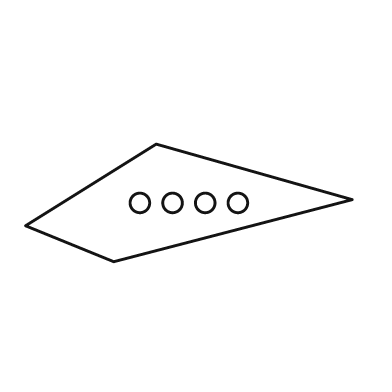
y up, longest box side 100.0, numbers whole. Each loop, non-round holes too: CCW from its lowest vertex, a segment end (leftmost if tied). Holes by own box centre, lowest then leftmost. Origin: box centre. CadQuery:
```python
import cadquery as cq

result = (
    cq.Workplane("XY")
    .moveTo(-23.0, -18.0)
    .lineTo(50.0, 1.0)
    .lineTo(-10.0, 18.0)
    .lineTo(-50.0, -7.0)
    .close()
    .moveTo(-15.0, 0.0)
    .circle(3.0)
    .moveTo(-5.0, 0.0)
    .circle(3.0)
    .moveTo(5.0, 0.0)
    .circle(3.0)
    .moveTo(15.0, 0.0)
    .circle(3.0)
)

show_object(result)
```